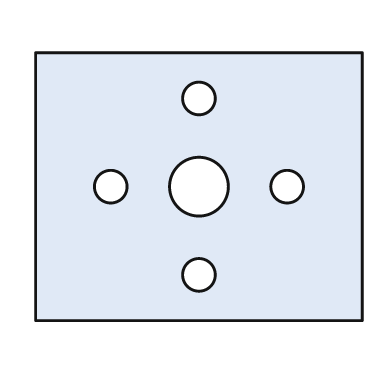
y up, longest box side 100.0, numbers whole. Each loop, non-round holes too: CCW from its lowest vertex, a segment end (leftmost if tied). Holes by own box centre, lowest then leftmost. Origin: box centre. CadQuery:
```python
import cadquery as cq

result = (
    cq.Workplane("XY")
    .moveTo(-50.0, -41.0)
    .lineTo(50.0, -41.0)
    .lineTo(50.0, 41.0)
    .lineTo(-50.0, 41.0)
    .close()
    .moveTo(0.0, -27.0)
    .circle(5.0)
    .moveTo(-27.0, 0.0)
    .circle(5.0)
    .moveTo(0.0, 0.0)
    .circle(9.0)
    .moveTo(27.0, 0.0)
    .circle(5.0)
    .moveTo(0.0, 27.0)
    .circle(5.0)
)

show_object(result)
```